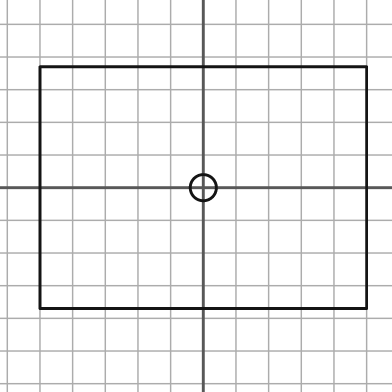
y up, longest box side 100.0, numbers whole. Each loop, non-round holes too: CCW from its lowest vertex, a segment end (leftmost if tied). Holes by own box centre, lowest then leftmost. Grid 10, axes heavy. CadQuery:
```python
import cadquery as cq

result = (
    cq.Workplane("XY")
    .moveTo(-50.0, -37.0)
    .lineTo(50.0, -37.0)
    .lineTo(50.0, 37.0)
    .lineTo(-50.0, 37.0)
    .close()
    .moveTo(0.0, 0.0)
    .circle(4.0)
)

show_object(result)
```